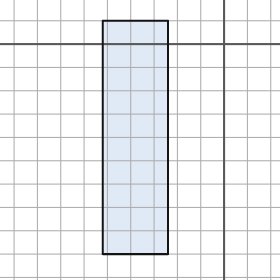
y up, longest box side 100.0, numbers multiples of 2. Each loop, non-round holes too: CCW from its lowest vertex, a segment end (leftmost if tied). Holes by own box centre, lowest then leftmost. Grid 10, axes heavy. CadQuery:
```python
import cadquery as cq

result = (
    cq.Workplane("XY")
    .moveTo(-52.0, -90.0)
    .lineTo(-24.0, -90.0)
    .lineTo(-24.0, 10.0)
    .lineTo(-52.0, 10.0)
    .close()
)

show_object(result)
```